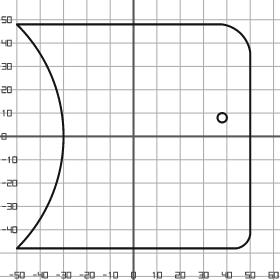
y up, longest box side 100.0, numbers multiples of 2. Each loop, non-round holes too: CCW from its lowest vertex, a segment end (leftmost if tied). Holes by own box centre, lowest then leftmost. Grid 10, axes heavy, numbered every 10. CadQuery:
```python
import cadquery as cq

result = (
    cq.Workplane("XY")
    .moveTo(-50.0, -48.0)
    .lineTo(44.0, -48.0)
    .threePointArc((48.0, -46.0), (50.0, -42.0))
    .lineTo(50.0, 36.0)
    .threePointArc((46.0, 44.0), (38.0, 48.0))
    .lineTo(-50.0, 48.0)
    .threePointArc((-30.0, 0.0), (-50.0, -48.0))
    .close()
    .moveTo(38.0, 8.0)
    .circle(2.0)
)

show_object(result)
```